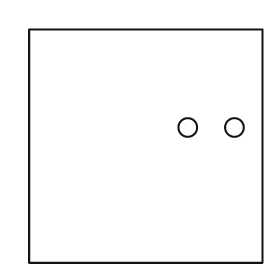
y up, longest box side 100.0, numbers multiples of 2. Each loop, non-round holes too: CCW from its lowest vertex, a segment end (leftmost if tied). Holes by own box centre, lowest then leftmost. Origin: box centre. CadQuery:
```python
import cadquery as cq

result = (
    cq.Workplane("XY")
    .moveTo(-50.0, -50.0)
    .lineTo(50.0, -50.0)
    .lineTo(50.0, 50.0)
    .lineTo(-50.0, 50.0)
    .close()
    .moveTo(18.0, 8.0)
    .circle(4.0)
    .moveTo(38.0, 8.0)
    .circle(4.0)
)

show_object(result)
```